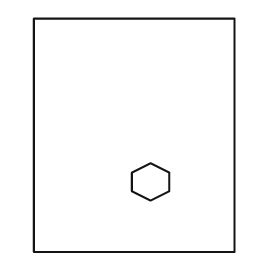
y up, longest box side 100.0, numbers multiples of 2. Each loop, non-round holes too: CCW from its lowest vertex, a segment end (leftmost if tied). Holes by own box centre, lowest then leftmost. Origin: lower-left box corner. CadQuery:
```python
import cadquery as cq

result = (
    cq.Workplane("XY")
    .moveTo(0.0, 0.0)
    .lineTo(86.0, 0.0)
    .lineTo(86.0, 100.0)
    .lineTo(0.0, 100.0)
    .close()
    .moveTo(50.0, 22.0)
    .lineTo(58.0, 26.0)
    .lineTo(58.0, 34.0)
    .lineTo(50.0, 38.0)
    .lineTo(42.0, 34.0)
    .lineTo(42.0, 26.0)
    .close()
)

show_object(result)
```